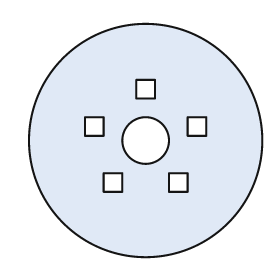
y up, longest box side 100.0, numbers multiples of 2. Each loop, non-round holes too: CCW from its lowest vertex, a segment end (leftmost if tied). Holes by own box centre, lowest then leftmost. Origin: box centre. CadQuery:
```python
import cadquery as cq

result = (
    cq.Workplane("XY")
    .moveTo(0.0, 0.0)
    .circle(50.0)
    .moveTo(-18.0, -22.0)
    .lineTo(-10.0, -22.0)
    .lineTo(-10.0, -14.0)
    .lineTo(-18.0, -14.0)
    .close()
    .moveTo(10.0, -22.0)
    .lineTo(18.0, -22.0)
    .lineTo(18.0, -14.0)
    .lineTo(10.0, -14.0)
    .close()
    .moveTo(0.0, 0.0)
    .circle(10.0)
    .moveTo(-26.0, 2.0)
    .lineTo(-18.0, 2.0)
    .lineTo(-18.0, 10.0)
    .lineTo(-26.0, 10.0)
    .close()
    .moveTo(18.0, 2.0)
    .lineTo(26.0, 2.0)
    .lineTo(26.0, 10.0)
    .lineTo(18.0, 10.0)
    .close()
    .moveTo(-4.0, 18.0)
    .lineTo(4.0, 18.0)
    .lineTo(4.0, 26.0)
    .lineTo(-4.0, 26.0)
    .close()
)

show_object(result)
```